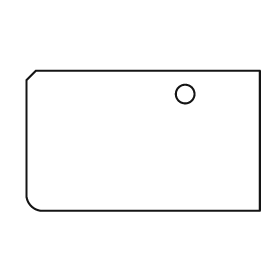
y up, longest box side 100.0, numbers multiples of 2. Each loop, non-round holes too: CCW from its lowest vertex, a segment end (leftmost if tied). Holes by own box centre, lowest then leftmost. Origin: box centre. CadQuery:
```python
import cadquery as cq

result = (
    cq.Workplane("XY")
    .moveTo(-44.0, -30.0)
    .lineTo(50.0, -30.0)
    .lineTo(50.0, 30.0)
    .lineTo(-46.0, 30.0)
    .lineTo(-50.0, 26.0)
    .lineTo(-50.0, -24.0)
    .threePointArc((-48.0, -28.0), (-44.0, -30.0))
    .close()
    .moveTo(18.0, 20.0)
    .circle(4.0)
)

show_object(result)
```